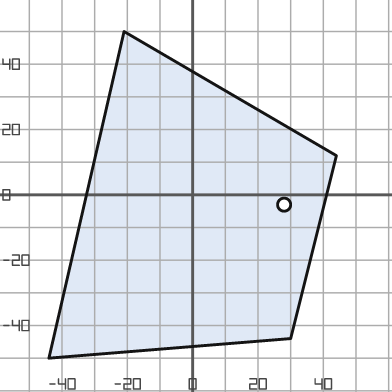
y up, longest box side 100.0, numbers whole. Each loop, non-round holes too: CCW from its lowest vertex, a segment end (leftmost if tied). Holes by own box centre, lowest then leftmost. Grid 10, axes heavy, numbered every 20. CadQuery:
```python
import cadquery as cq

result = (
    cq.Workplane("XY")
    .moveTo(-44.0, -50.0)
    .lineTo(30.0, -44.0)
    .lineTo(44.0, 12.0)
    .lineTo(-21.0, 50.0)
    .close()
    .moveTo(28.0, -3.0)
    .circle(2.0)
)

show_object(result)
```